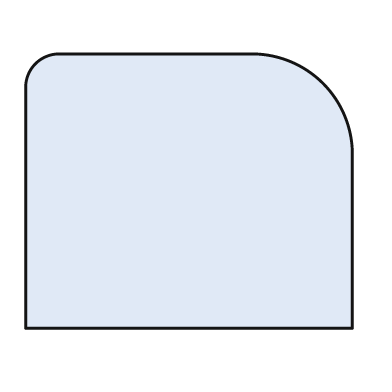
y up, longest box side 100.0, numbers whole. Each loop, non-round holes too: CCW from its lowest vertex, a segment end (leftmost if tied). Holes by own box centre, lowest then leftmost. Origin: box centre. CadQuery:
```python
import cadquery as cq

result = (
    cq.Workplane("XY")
    .moveTo(-50.0, -42.0)
    .lineTo(50.0, -42.0)
    .lineTo(50.0, 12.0)
    .threePointArc((41.0, 33.0), (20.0, 42.0))
    .lineTo(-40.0, 42.0)
    .threePointArc((-47.0, 39.0), (-50.0, 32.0))
    .close()
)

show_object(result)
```